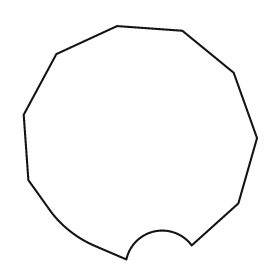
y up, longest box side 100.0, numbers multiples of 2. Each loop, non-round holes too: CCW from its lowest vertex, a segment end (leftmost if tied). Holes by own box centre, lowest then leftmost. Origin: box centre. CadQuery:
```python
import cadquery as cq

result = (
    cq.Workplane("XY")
    .moveTo(-6.0, -50.0)
    .threePointArc((6.0, -38.0), (22.0, -44.0))
    .lineTo(42.0, -26.0)
    .lineTo(50.0, 2.0)
    .lineTo(40.0, 30.0)
    .lineTo(18.0, 48.0)
    .lineTo(-10.0, 50.0)
    .lineTo(-36.0, 38.0)
    .lineTo(-50.0, 12.0)
    .lineTo(-48.0, -16.0)
    .lineTo(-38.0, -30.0)
    .threePointArc((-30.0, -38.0), (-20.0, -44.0))
    .close()
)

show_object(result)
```